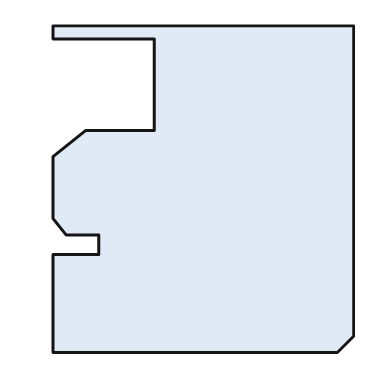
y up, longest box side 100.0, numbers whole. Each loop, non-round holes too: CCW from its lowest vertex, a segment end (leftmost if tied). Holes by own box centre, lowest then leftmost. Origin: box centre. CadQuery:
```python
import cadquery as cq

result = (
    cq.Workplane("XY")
    .moveTo(-46.0, -50.0)
    .lineTo(41.0, -50.0)
    .lineTo(46.0, -45.0)
    .lineTo(46.0, 50.0)
    .lineTo(-46.0, 50.0)
    .lineTo(-46.0, 46.0)
    .lineTo(-15.0, 46.0)
    .lineTo(-15.0, 18.0)
    .lineTo(-36.0, 18.0)
    .lineTo(-46.0, 10.0)
    .lineTo(-46.0, -9.0)
    .lineTo(-42.0, -14.0)
    .lineTo(-32.0, -14.0)
    .lineTo(-32.0, -20.0)
    .lineTo(-46.0, -20.0)
    .close()
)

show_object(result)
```